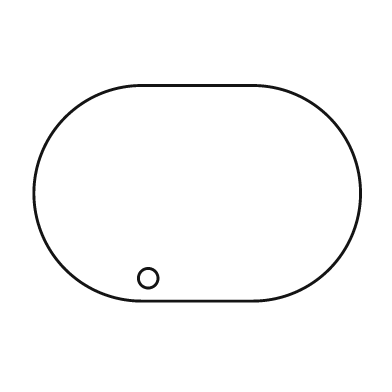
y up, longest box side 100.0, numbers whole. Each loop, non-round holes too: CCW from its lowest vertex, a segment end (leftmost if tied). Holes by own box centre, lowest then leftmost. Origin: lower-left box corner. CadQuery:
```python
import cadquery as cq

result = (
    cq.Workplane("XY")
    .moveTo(33.0, 0.0)
    .lineTo(67.0, 0.0)
    .threePointArc((100.0, 33.0), (67.0, 66.0))
    .lineTo(33.0, 66.0)
    .threePointArc((0.0, 33.0), (33.0, 0.0))
    .close()
    .moveTo(35.0, 7.0)
    .circle(3.0)
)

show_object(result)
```